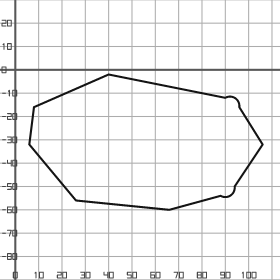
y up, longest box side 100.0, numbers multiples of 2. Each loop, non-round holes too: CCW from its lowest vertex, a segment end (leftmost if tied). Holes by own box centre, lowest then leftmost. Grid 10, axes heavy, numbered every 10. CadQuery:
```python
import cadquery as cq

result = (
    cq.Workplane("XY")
    .moveTo(66.0, -60.0)
    .lineTo(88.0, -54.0)
    .threePointArc((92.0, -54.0), (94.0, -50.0))
    .lineTo(106.0, -32.0)
    .lineTo(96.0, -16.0)
    .threePointArc((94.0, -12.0), (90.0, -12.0))
    .lineTo(40.0, -2.0)
    .lineTo(8.0, -16.0)
    .lineTo(6.0, -32.0)
    .lineTo(26.0, -56.0)
    .close()
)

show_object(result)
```